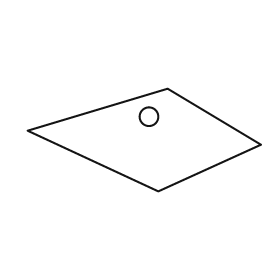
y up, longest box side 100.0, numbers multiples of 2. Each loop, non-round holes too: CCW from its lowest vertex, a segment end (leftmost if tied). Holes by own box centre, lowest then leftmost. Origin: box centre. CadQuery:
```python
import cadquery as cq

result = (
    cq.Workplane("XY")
    .moveTo(6.0, -22.0)
    .lineTo(50.0, -2.0)
    .lineTo(10.0, 22.0)
    .lineTo(-50.0, 4.0)
    .close()
    .moveTo(2.0, 10.0)
    .circle(4.0)
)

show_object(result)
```